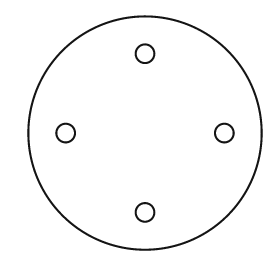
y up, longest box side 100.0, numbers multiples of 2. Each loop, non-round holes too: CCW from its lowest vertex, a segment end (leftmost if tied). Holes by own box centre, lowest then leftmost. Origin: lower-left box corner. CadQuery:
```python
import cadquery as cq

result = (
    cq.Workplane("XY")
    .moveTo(50.0, 50.0)
    .circle(50.0)
    .moveTo(50.0, 16.0)
    .circle(4.0)
    .moveTo(16.0, 50.0)
    .circle(4.0)
    .moveTo(84.0, 50.0)
    .circle(4.0)
    .moveTo(50.0, 84.0)
    .circle(4.0)
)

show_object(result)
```